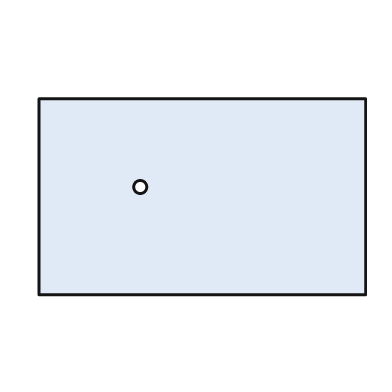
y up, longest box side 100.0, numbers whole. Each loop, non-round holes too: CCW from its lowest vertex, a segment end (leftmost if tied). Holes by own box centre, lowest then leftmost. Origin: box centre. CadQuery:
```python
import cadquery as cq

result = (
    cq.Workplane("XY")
    .moveTo(-50.0, -30.0)
    .lineTo(50.0, -30.0)
    .lineTo(50.0, 30.0)
    .lineTo(-50.0, 30.0)
    .close()
    .moveTo(-19.0, 3.0)
    .circle(2.0)
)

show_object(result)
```